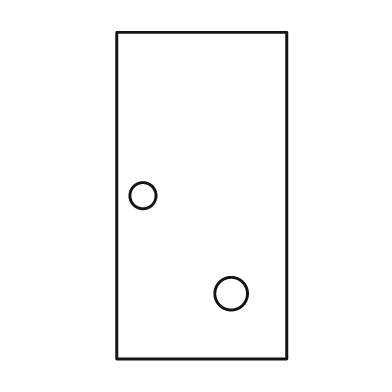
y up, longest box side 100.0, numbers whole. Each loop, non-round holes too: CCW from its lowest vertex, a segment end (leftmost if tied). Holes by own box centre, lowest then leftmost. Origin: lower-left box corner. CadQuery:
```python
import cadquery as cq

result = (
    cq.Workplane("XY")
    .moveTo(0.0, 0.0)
    .lineTo(52.0, 0.0)
    .lineTo(52.0, 100.0)
    .lineTo(0.0, 100.0)
    .close()
    .moveTo(35.0, 20.0)
    .circle(5.0)
    .moveTo(8.0, 50.0)
    .circle(4.0)
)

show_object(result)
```